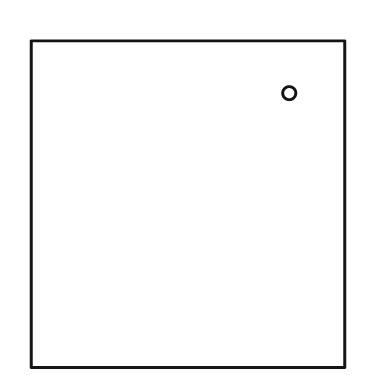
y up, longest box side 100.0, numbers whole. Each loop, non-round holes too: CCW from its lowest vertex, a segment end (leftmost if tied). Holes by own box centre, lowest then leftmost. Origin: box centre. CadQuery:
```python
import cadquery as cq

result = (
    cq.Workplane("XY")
    .moveTo(-48.0, -50.0)
    .lineTo(48.0, -50.0)
    .lineTo(48.0, 50.0)
    .lineTo(-48.0, 50.0)
    .close()
    .moveTo(31.0, 34.0)
    .circle(2.0)
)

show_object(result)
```